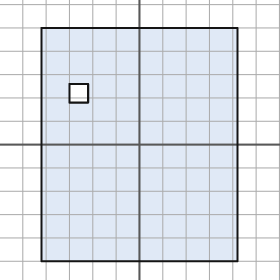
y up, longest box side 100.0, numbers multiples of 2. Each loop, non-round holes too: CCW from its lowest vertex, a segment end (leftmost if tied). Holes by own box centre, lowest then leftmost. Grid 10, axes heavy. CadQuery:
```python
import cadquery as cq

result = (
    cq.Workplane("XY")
    .moveTo(-42.0, -50.0)
    .lineTo(42.0, -50.0)
    .lineTo(42.0, 50.0)
    .lineTo(-42.0, 50.0)
    .close()
    .moveTo(-30.0, 18.0)
    .lineTo(-22.0, 18.0)
    .lineTo(-22.0, 26.0)
    .lineTo(-30.0, 26.0)
    .close()
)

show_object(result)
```